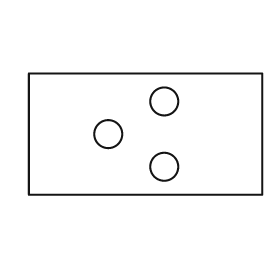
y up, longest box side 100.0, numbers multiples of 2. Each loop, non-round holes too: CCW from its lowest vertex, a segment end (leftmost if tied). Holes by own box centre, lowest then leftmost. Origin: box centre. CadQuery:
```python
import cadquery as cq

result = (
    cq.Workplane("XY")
    .moveTo(-50.0, -26.0)
    .lineTo(50.0, -26.0)
    .lineTo(50.0, 26.0)
    .lineTo(-50.0, 26.0)
    .close()
    .moveTo(8.0, -14.0)
    .circle(6.0)
    .moveTo(-16.0, 0.0)
    .circle(6.0)
    .moveTo(8.0, 14.0)
    .circle(6.0)
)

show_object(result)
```